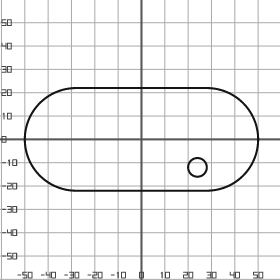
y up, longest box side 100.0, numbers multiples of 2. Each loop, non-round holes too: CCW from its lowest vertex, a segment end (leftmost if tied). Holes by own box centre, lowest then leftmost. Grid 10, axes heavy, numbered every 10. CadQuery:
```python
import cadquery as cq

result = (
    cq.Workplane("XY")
    .moveTo(-28.0, -22.0)
    .lineTo(28.0, -22.0)
    .threePointArc((50.0, 0.0), (28.0, 22.0))
    .lineTo(-28.0, 22.0)
    .threePointArc((-50.0, 0.0), (-28.0, -22.0))
    .close()
    .moveTo(24.0, -12.0)
    .circle(4.0)
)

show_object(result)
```